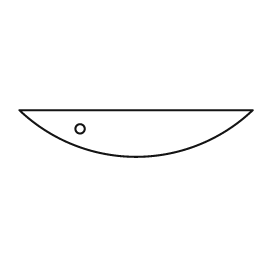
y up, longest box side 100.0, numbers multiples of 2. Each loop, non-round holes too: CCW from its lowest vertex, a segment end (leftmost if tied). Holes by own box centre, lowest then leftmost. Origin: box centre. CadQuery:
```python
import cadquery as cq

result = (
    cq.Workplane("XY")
    .moveTo(-50.0, 10.0)
    .threePointArc((0.0, -10.0), (50.0, 10.0))
    .close()
    .moveTo(-24.0, 2.0)
    .circle(2.0)
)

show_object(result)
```